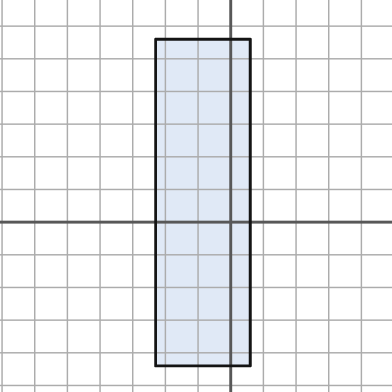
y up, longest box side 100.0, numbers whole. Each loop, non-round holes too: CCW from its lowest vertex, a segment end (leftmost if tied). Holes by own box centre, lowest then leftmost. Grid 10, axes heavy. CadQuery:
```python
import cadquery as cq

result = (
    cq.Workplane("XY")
    .moveTo(-23.0, -44.0)
    .lineTo(6.0, -44.0)
    .lineTo(6.0, 56.0)
    .lineTo(-23.0, 56.0)
    .close()
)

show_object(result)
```